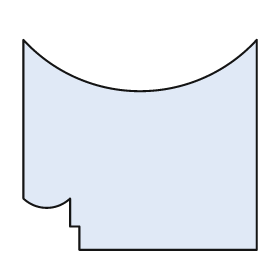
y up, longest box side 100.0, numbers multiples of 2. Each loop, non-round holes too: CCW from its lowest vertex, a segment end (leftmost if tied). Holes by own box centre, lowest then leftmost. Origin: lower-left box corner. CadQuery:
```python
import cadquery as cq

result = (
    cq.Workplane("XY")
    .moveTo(24.0, 0.0)
    .lineTo(100.0, 0.0)
    .lineTo(100.0, 90.0)
    .threePointArc((50.0, 68.0), (0.0, 90.0))
    .lineTo(0.0, 22.0)
    .threePointArc((10.0, 18.0), (20.0, 22.0))
    .lineTo(20.0, 10.0)
    .lineTo(24.0, 10.0)
    .close()
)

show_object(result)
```